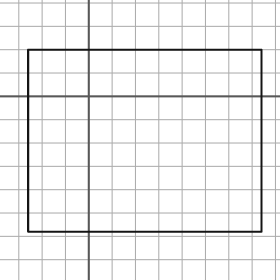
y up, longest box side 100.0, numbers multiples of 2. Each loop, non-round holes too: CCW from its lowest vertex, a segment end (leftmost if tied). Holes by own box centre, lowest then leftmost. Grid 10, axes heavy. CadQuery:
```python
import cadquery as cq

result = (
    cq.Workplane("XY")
    .moveTo(-26.0, -58.0)
    .lineTo(74.0, -58.0)
    .lineTo(74.0, 20.0)
    .lineTo(-26.0, 20.0)
    .close()
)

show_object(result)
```